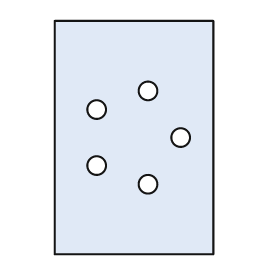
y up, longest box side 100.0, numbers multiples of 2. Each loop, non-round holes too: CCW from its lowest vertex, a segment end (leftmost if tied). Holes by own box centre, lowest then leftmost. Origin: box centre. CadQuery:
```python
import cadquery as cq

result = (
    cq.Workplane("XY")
    .moveTo(-34.0, -50.0)
    .lineTo(34.0, -50.0)
    .lineTo(34.0, 50.0)
    .lineTo(-34.0, 50.0)
    .close()
    .moveTo(6.0, -20.0)
    .circle(4.0)
    .moveTo(-16.0, -12.0)
    .circle(4.0)
    .moveTo(20.0, 0.0)
    .circle(4.0)
    .moveTo(-16.0, 12.0)
    .circle(4.0)
    .moveTo(6.0, 20.0)
    .circle(4.0)
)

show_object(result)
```